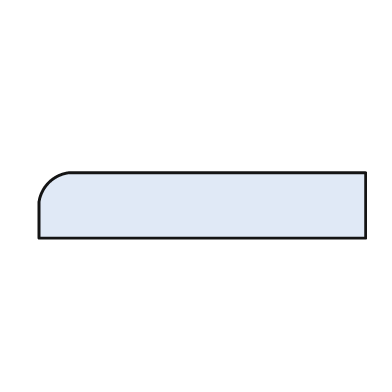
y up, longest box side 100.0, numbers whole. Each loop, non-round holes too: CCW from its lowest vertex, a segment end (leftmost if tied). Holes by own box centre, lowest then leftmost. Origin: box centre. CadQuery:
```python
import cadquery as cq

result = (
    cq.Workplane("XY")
    .moveTo(-50.0, -10.0)
    .lineTo(50.0, -10.0)
    .lineTo(50.0, 10.0)
    .lineTo(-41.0, 10.0)
    .threePointArc((-47.0, 7.0), (-50.0, 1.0))
    .close()
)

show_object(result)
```